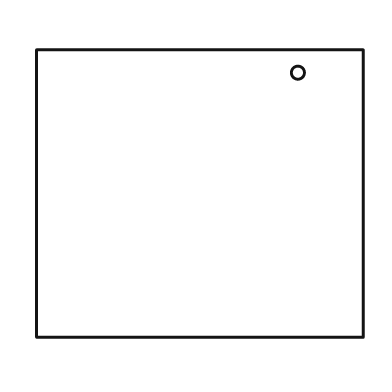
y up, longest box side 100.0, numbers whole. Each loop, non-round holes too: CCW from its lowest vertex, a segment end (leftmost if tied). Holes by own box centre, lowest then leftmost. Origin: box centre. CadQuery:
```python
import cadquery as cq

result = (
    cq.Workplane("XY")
    .moveTo(-50.0, -44.0)
    .lineTo(50.0, -44.0)
    .lineTo(50.0, 44.0)
    .lineTo(-50.0, 44.0)
    .close()
    .moveTo(30.0, 37.0)
    .circle(2.0)
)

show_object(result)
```